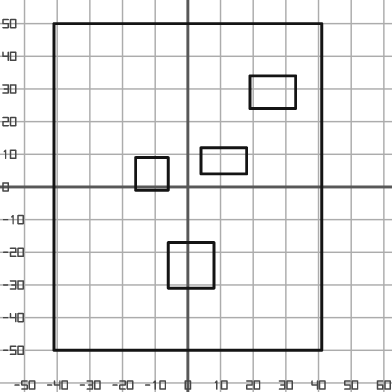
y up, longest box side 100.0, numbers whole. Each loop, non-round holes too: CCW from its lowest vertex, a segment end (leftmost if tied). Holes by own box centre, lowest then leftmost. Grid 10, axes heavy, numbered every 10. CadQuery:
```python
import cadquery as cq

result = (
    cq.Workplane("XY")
    .moveTo(-41.0, -50.0)
    .lineTo(41.0, -50.0)
    .lineTo(41.0, 50.0)
    .lineTo(-41.0, 50.0)
    .close()
    .moveTo(-6.0, -31.0)
    .lineTo(8.0, -31.0)
    .lineTo(8.0, -17.0)
    .lineTo(-6.0, -17.0)
    .close()
    .moveTo(-16.0, -1.0)
    .lineTo(-6.0, -1.0)
    .lineTo(-6.0, 9.0)
    .lineTo(-16.0, 9.0)
    .close()
    .moveTo(4.0, 4.0)
    .lineTo(18.0, 4.0)
    .lineTo(18.0, 12.0)
    .lineTo(4.0, 12.0)
    .close()
    .moveTo(19.0, 24.0)
    .lineTo(33.0, 24.0)
    .lineTo(33.0, 34.0)
    .lineTo(19.0, 34.0)
    .close()
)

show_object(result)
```